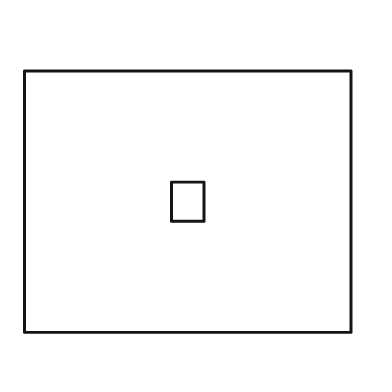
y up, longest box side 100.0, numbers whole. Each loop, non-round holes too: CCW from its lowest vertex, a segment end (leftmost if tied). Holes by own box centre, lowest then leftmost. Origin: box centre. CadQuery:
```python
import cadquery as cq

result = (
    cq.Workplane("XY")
    .moveTo(-50.0, -40.0)
    .lineTo(50.0, -40.0)
    .lineTo(50.0, 40.0)
    .lineTo(-50.0, 40.0)
    .close()
    .moveTo(-5.0, -6.0)
    .lineTo(5.0, -6.0)
    .lineTo(5.0, 6.0)
    .lineTo(-5.0, 6.0)
    .close()
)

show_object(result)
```